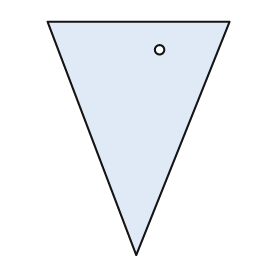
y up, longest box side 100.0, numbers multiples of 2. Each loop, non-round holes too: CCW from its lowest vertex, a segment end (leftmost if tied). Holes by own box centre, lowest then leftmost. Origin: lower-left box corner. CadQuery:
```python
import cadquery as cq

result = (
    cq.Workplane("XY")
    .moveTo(38.0, 0.0)
    .lineTo(78.0, 100.0)
    .lineTo(0.0, 100.0)
    .close()
    .moveTo(48.0, 88.0)
    .circle(2.0)
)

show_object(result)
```